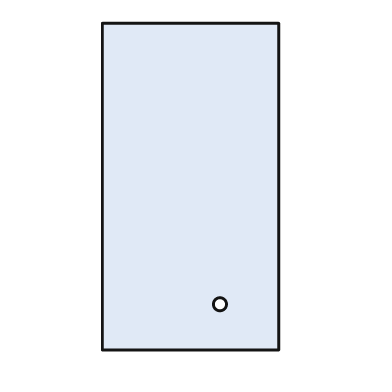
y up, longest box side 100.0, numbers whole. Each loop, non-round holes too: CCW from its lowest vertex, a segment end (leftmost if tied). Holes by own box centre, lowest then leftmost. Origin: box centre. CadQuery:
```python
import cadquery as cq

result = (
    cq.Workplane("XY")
    .moveTo(-27.0, -50.0)
    .lineTo(27.0, -50.0)
    .lineTo(27.0, 50.0)
    .lineTo(-27.0, 50.0)
    .close()
    .moveTo(9.0, -36.0)
    .circle(2.0)
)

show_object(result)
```